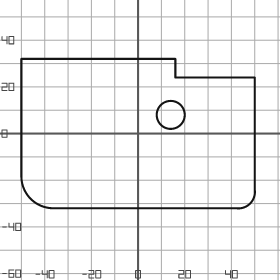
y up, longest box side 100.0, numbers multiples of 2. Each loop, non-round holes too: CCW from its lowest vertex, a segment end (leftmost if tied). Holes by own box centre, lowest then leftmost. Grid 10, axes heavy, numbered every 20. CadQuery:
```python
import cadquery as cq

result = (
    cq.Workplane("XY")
    .moveTo(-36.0, -32.0)
    .lineTo(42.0, -32.0)
    .threePointArc((48.0, -30.0), (50.0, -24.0))
    .lineTo(50.0, 24.0)
    .lineTo(16.0, 24.0)
    .lineTo(16.0, 32.0)
    .lineTo(-50.0, 32.0)
    .lineTo(-50.0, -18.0)
    .threePointArc((-46.0, -28.0), (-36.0, -32.0))
    .close()
    .moveTo(14.0, 8.0)
    .circle(6.0)
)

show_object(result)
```